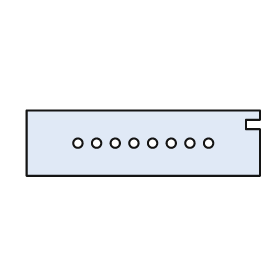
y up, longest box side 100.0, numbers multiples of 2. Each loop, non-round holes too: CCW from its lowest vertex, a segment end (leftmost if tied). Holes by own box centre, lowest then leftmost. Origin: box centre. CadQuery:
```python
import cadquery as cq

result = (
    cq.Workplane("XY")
    .moveTo(-50.0, -14.0)
    .lineTo(50.0, -14.0)
    .lineTo(50.0, 6.0)
    .lineTo(44.0, 6.0)
    .lineTo(44.0, 10.0)
    .lineTo(50.0, 10.0)
    .lineTo(50.0, 14.0)
    .lineTo(-50.0, 14.0)
    .close()
    .moveTo(-28.0, 0.0)
    .circle(2.0)
    .moveTo(-20.0, 0.0)
    .circle(2.0)
    .moveTo(-12.0, 0.0)
    .circle(2.0)
    .moveTo(-4.0, 0.0)
    .circle(2.0)
    .moveTo(4.0, 0.0)
    .circle(2.0)
    .moveTo(12.0, 0.0)
    .circle(2.0)
    .moveTo(20.0, 0.0)
    .circle(2.0)
    .moveTo(28.0, 0.0)
    .circle(2.0)
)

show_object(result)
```